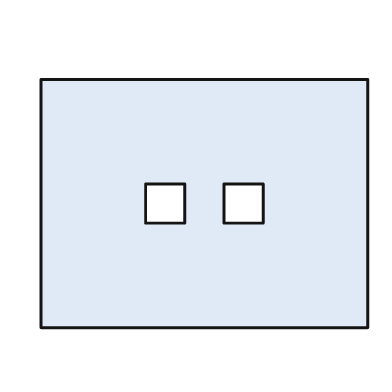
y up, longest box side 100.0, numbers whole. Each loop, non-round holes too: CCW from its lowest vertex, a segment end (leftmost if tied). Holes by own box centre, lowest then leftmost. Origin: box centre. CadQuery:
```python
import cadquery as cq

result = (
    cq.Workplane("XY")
    .moveTo(-50.0, -38.0)
    .lineTo(50.0, -38.0)
    .lineTo(50.0, 38.0)
    .lineTo(-50.0, 38.0)
    .close()
    .moveTo(-18.0, -6.0)
    .lineTo(-6.0, -6.0)
    .lineTo(-6.0, 6.0)
    .lineTo(-18.0, 6.0)
    .close()
    .moveTo(6.0, -6.0)
    .lineTo(18.0, -6.0)
    .lineTo(18.0, 6.0)
    .lineTo(6.0, 6.0)
    .close()
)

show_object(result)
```